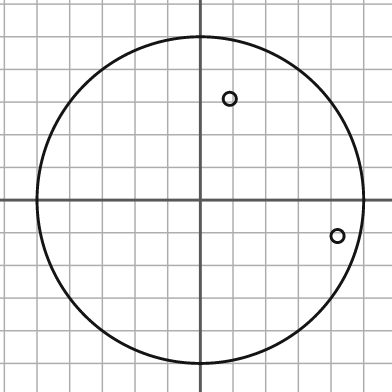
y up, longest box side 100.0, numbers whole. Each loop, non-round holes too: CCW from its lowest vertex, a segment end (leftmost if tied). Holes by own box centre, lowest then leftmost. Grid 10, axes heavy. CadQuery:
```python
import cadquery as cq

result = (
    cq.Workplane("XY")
    .moveTo(0.0, 0.0)
    .circle(50.0)
    .moveTo(42.0, -11.0)
    .circle(2.0)
    .moveTo(9.0, 31.0)
    .circle(2.0)
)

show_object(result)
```